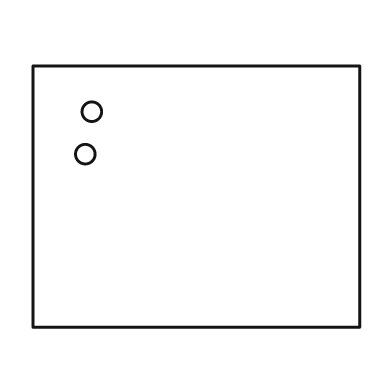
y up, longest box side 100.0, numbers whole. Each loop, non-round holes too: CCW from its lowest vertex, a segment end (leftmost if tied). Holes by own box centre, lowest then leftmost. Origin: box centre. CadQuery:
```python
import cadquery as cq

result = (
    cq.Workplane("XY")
    .moveTo(-50.0, -40.0)
    .lineTo(50.0, -40.0)
    .lineTo(50.0, 40.0)
    .lineTo(-50.0, 40.0)
    .close()
    .moveTo(-34.0, 13.0)
    .circle(3.0)
    .moveTo(-32.0, 26.0)
    .circle(3.0)
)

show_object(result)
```